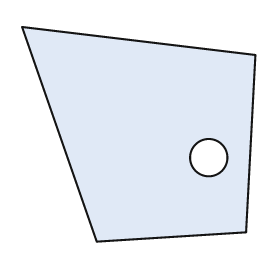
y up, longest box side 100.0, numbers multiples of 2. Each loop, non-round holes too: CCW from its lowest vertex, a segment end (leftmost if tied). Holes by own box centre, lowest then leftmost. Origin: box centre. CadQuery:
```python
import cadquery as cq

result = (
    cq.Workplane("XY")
    .moveTo(-18.0, -46.0)
    .lineTo(46.0, -42.0)
    .lineTo(50.0, 34.0)
    .lineTo(-50.0, 46.0)
    .close()
    .moveTo(30.0, -10.0)
    .circle(8.0)
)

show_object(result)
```